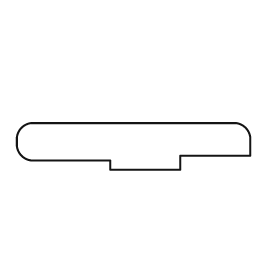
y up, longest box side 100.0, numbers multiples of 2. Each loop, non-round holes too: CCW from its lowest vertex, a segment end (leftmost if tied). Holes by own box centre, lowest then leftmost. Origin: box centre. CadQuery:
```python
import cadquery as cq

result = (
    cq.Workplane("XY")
    .moveTo(-10.0, -10.0)
    .lineTo(20.0, -10.0)
    .lineTo(20.0, -4.0)
    .lineTo(50.0, -4.0)
    .lineTo(50.0, 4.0)
    .threePointArc((48.0, 8.0), (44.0, 10.0))
    .lineTo(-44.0, 10.0)
    .threePointArc((-48.0, 8.0), (-50.0, 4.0))
    .lineTo(-50.0, 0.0)
    .threePointArc((-48.0, -4.0), (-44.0, -6.0))
    .lineTo(-10.0, -6.0)
    .close()
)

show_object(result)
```